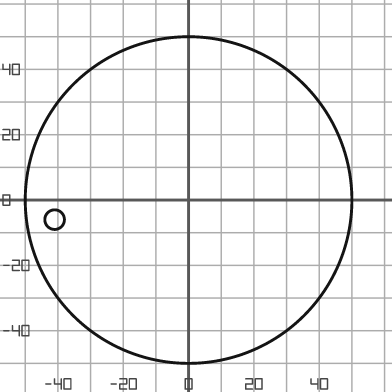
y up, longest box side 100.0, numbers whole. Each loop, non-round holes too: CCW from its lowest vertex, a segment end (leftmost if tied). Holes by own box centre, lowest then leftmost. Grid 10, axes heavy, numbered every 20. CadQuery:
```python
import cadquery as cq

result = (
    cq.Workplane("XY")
    .moveTo(0.0, 0.0)
    .circle(50.0)
    .moveTo(-41.0, -6.0)
    .circle(3.0)
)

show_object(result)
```